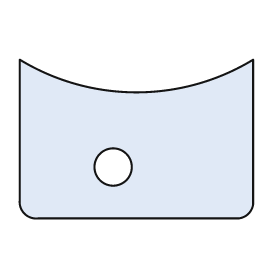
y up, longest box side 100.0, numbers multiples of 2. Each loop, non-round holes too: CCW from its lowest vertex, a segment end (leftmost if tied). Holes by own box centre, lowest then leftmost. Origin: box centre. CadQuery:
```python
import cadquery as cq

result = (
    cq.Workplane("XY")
    .moveTo(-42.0, -34.0)
    .lineTo(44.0, -34.0)
    .threePointArc((48.0, -32.0), (50.0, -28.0))
    .lineTo(50.0, 34.0)
    .threePointArc((0.0, 20.0), (-50.0, 34.0))
    .lineTo(-50.0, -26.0)
    .threePointArc((-48.0, -32.0), (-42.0, -34.0))
    .close()
    .moveTo(-10.0, -12.0)
    .circle(8.0)
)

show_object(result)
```